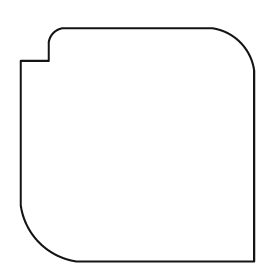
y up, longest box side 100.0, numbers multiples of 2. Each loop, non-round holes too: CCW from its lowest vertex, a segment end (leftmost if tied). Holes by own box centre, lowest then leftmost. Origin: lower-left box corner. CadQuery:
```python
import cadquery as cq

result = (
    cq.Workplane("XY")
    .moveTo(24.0, 0.0)
    .lineTo(100.0, 0.0)
    .lineTo(100.0, 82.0)
    .threePointArc((94.0, 94.0), (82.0, 100.0))
    .lineTo(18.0, 100.0)
    .threePointArc((14.0, 98.0), (12.0, 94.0))
    .lineTo(12.0, 86.0)
    .lineTo(0.0, 86.0)
    .lineTo(0.0, 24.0)
    .threePointArc((8.0, 8.0), (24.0, 0.0))
    .close()
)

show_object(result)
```